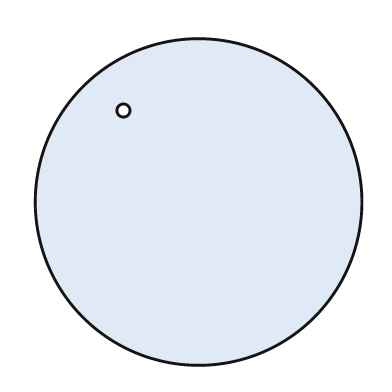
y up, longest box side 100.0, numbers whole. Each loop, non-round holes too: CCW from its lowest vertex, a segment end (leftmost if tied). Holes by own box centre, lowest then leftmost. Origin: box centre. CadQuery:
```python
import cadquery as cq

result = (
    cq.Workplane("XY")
    .moveTo(0.0, 0.0)
    .circle(50.0)
    .moveTo(-23.0, 28.0)
    .circle(2.0)
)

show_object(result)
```